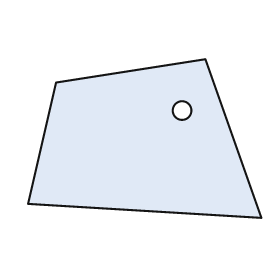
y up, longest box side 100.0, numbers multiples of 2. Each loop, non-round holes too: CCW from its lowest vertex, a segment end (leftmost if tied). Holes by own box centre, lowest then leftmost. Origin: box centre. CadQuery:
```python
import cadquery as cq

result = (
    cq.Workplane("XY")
    .moveTo(50.0, -34.0)
    .lineTo(26.0, 34.0)
    .lineTo(-38.0, 24.0)
    .lineTo(-50.0, -28.0)
    .close()
    .moveTo(16.0, 12.0)
    .circle(4.0)
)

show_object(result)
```